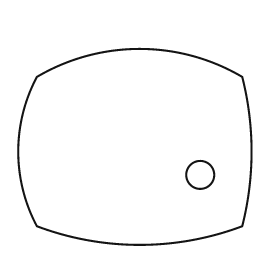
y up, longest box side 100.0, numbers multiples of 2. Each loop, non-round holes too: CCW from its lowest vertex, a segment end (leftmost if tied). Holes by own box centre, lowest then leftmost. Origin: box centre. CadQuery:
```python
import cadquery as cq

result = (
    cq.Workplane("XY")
    .moveTo(-42.0, -34.0)
    .threePointArc((2.0, -42.0), (46.0, -34.0))
    .threePointArc((50.0, -2.0), (46.0, 30.0))
    .threePointArc((2.0, 42.0), (-42.0, 30.0))
    .threePointArc((-50.0, -2.0), (-42.0, -34.0))
    .close()
    .moveTo(28.0, -12.0)
    .circle(6.0)
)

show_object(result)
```